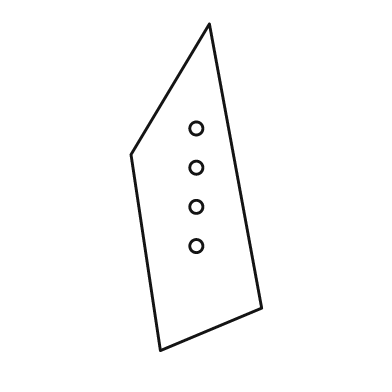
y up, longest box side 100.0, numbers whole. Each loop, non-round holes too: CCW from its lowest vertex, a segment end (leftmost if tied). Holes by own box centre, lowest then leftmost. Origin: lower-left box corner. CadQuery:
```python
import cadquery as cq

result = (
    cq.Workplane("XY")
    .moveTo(9.0, 0.0)
    .lineTo(40.0, 13.0)
    .lineTo(24.0, 100.0)
    .lineTo(0.0, 60.0)
    .close()
    .moveTo(20.0, 32.0)
    .circle(2.0)
    .moveTo(20.0, 44.0)
    .circle(2.0)
    .moveTo(20.0, 56.0)
    .circle(2.0)
    .moveTo(20.0, 68.0)
    .circle(2.0)
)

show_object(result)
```